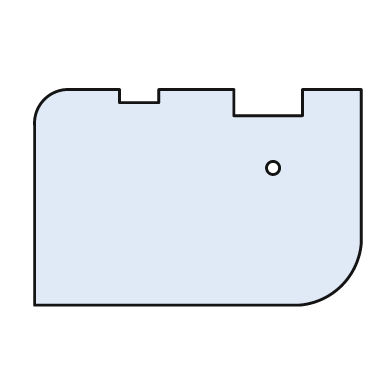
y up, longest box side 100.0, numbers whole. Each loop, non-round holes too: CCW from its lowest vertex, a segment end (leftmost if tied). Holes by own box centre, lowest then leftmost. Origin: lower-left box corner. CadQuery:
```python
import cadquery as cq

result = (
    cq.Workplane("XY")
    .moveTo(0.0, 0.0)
    .lineTo(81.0, 0.0)
    .threePointArc((94.0, 6.0), (100.0, 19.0))
    .lineTo(100.0, 66.0)
    .lineTo(82.0, 66.0)
    .lineTo(82.0, 58.0)
    .lineTo(61.0, 58.0)
    .lineTo(61.0, 66.0)
    .lineTo(38.0, 66.0)
    .lineTo(38.0, 62.0)
    .lineTo(26.0, 62.0)
    .lineTo(26.0, 66.0)
    .lineTo(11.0, 66.0)
    .threePointArc((3.0, 63.0), (0.0, 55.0))
    .close()
    .moveTo(73.0, 42.0)
    .circle(2.0)
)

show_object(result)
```